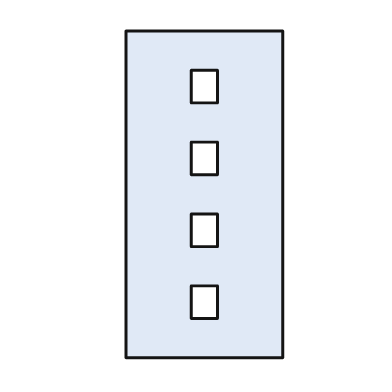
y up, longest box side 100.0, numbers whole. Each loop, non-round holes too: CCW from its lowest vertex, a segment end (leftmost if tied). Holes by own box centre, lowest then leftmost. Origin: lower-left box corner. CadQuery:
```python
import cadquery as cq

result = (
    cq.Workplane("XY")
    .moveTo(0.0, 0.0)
    .lineTo(48.0, 0.0)
    .lineTo(48.0, 100.0)
    .lineTo(0.0, 100.0)
    .close()
    .moveTo(20.0, 12.0)
    .lineTo(28.0, 12.0)
    .lineTo(28.0, 22.0)
    .lineTo(20.0, 22.0)
    .close()
    .moveTo(20.0, 34.0)
    .lineTo(28.0, 34.0)
    .lineTo(28.0, 44.0)
    .lineTo(20.0, 44.0)
    .close()
    .moveTo(20.0, 56.0)
    .lineTo(28.0, 56.0)
    .lineTo(28.0, 66.0)
    .lineTo(20.0, 66.0)
    .close()
    .moveTo(20.0, 78.0)
    .lineTo(28.0, 78.0)
    .lineTo(28.0, 88.0)
    .lineTo(20.0, 88.0)
    .close()
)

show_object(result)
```